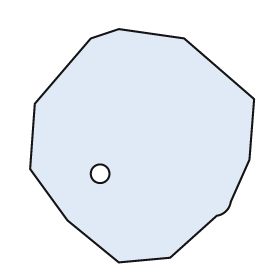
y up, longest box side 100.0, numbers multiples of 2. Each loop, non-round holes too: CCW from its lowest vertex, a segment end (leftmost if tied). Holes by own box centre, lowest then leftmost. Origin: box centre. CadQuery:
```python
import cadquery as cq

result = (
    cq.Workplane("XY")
    .moveTo(-10.0, -50.0)
    .lineTo(12.0, -48.0)
    .lineTo(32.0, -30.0)
    .threePointArc((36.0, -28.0), (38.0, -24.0))
    .lineTo(46.0, -6.0)
    .lineTo(48.0, 20.0)
    .lineTo(18.0, 46.0)
    .lineTo(-10.0, 50.0)
    .lineTo(-22.0, 46.0)
    .lineTo(-46.0, 18.0)
    .lineTo(-48.0, -10.0)
    .lineTo(-32.0, -32.0)
    .close()
    .moveTo(-18.0, -12.0)
    .circle(4.0)
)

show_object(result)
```